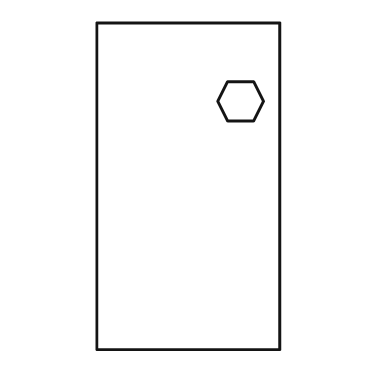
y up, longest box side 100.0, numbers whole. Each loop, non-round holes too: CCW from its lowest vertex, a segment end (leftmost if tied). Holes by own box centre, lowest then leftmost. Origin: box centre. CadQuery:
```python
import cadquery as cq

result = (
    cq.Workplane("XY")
    .moveTo(-28.0, -50.0)
    .lineTo(28.0, -50.0)
    .lineTo(28.0, 50.0)
    .lineTo(-28.0, 50.0)
    .close()
    .moveTo(12.0, 20.0)
    .lineTo(20.0, 20.0)
    .lineTo(23.0, 26.0)
    .lineTo(20.0, 32.0)
    .lineTo(12.0, 32.0)
    .lineTo(9.0, 26.0)
    .close()
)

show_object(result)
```